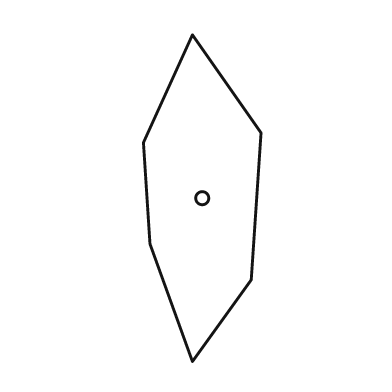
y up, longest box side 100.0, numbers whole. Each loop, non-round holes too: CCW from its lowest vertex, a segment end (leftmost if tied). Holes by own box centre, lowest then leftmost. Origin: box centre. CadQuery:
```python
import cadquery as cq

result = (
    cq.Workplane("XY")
    .moveTo(-3.0, -50.0)
    .lineTo(15.0, -25.0)
    .lineTo(18.0, 20.0)
    .lineTo(-3.0, 50.0)
    .lineTo(-18.0, 17.0)
    .lineTo(-16.0, -14.0)
    .close()
    .moveTo(0.0, 0.0)
    .circle(2.0)
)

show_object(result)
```